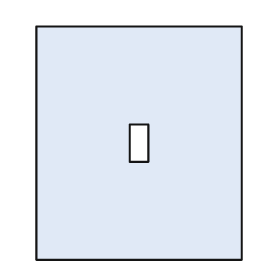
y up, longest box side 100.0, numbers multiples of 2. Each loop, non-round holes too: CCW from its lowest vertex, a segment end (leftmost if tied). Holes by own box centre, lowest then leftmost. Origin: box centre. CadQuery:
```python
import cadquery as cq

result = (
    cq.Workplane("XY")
    .moveTo(-44.0, -50.0)
    .lineTo(44.0, -50.0)
    .lineTo(44.0, 50.0)
    .lineTo(-44.0, 50.0)
    .close()
    .moveTo(-4.0, -8.0)
    .lineTo(4.0, -8.0)
    .lineTo(4.0, 8.0)
    .lineTo(-4.0, 8.0)
    .close()
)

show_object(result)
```